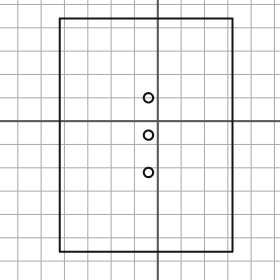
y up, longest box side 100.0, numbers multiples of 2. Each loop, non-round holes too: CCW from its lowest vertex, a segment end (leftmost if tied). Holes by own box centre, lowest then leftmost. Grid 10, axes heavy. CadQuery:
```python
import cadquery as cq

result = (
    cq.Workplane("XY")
    .moveTo(-42.0, -56.0)
    .lineTo(32.0, -56.0)
    .lineTo(32.0, 44.0)
    .lineTo(-42.0, 44.0)
    .close()
    .moveTo(-4.0, -22.0)
    .circle(2.0)
    .moveTo(-4.0, -6.0)
    .circle(2.0)
    .moveTo(-4.0, 10.0)
    .circle(2.0)
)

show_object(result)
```